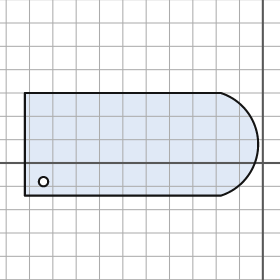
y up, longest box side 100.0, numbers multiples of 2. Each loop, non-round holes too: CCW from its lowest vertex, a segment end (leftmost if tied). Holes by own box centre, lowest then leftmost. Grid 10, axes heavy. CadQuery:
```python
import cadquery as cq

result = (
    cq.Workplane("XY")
    .moveTo(-102.0, -14.0)
    .lineTo(-18.0, -14.0)
    .threePointArc((-2.0, 8.0), (-18.0, 30.0))
    .lineTo(-102.0, 30.0)
    .close()
    .moveTo(-94.0, -8.0)
    .circle(2.0)
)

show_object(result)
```